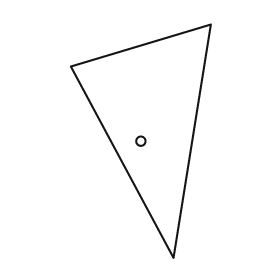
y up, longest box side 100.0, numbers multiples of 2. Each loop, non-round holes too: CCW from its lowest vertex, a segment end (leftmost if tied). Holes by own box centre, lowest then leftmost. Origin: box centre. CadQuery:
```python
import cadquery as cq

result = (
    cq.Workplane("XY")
    .moveTo(14.0, -50.0)
    .lineTo(30.0, 50.0)
    .lineTo(-30.0, 32.0)
    .close()
    .moveTo(0.0, 0.0)
    .circle(2.0)
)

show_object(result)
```